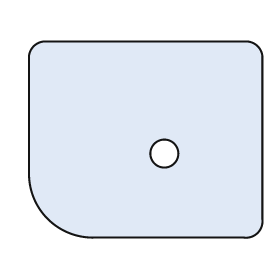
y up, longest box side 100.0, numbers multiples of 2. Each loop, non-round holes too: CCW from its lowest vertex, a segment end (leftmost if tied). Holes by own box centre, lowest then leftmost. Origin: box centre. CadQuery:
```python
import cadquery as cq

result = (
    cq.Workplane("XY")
    .moveTo(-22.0, -42.0)
    .lineTo(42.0, -42.0)
    .threePointArc((48.0, -40.0), (50.0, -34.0))
    .lineTo(50.0, 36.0)
    .threePointArc((48.0, 40.0), (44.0, 42.0))
    .lineTo(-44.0, 42.0)
    .threePointArc((-48.0, 40.0), (-50.0, 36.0))
    .lineTo(-50.0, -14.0)
    .threePointArc((-42.0, -34.0), (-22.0, -42.0))
    .close()
    .moveTo(8.0, -6.0)
    .circle(6.0)
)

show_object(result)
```